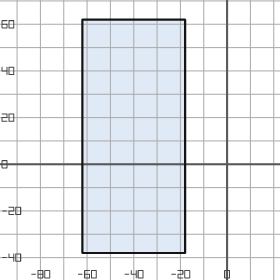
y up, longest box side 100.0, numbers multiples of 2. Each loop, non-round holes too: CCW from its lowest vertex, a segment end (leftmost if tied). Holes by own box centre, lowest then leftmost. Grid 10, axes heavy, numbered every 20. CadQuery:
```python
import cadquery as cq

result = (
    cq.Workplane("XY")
    .moveTo(-62.0, -38.0)
    .lineTo(-18.0, -38.0)
    .lineTo(-18.0, 62.0)
    .lineTo(-62.0, 62.0)
    .close()
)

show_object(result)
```